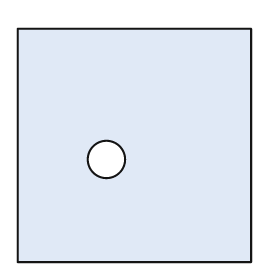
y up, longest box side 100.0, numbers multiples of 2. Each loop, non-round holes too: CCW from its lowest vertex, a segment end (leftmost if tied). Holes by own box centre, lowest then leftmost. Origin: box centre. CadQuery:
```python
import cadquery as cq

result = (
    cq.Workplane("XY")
    .moveTo(-50.0, -50.0)
    .lineTo(50.0, -50.0)
    .lineTo(50.0, 50.0)
    .lineTo(-50.0, 50.0)
    .close()
    .moveTo(-12.0, -6.0)
    .circle(8.0)
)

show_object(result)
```